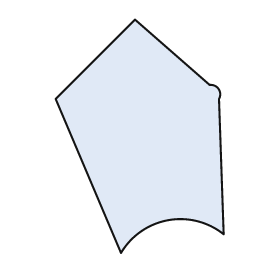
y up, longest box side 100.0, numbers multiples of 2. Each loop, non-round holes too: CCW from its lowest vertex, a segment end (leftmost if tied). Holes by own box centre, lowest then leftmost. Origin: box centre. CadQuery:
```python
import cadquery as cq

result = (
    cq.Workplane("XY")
    .moveTo(-8.0, -50.0)
    .threePointArc((12.0, -36.0), (36.0, -42.0))
    .lineTo(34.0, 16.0)
    .threePointArc((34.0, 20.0), (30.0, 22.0))
    .lineTo(-2.0, 50.0)
    .lineTo(-36.0, 16.0)
    .close()
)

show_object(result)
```